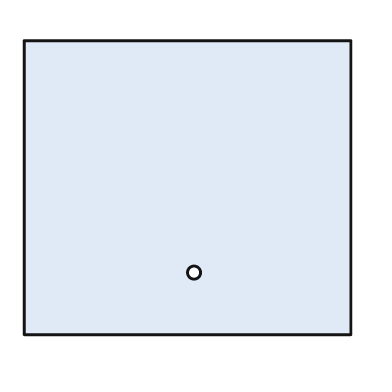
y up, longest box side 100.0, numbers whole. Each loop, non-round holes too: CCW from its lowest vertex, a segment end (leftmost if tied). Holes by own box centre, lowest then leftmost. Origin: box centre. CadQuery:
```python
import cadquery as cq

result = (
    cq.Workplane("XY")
    .moveTo(-50.0, -45.0)
    .lineTo(50.0, -45.0)
    .lineTo(50.0, 45.0)
    .lineTo(-50.0, 45.0)
    .close()
    .moveTo(2.0, -26.0)
    .circle(2.0)
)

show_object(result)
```